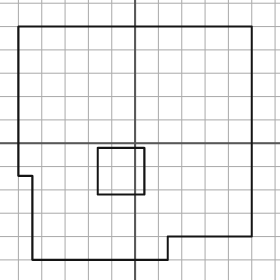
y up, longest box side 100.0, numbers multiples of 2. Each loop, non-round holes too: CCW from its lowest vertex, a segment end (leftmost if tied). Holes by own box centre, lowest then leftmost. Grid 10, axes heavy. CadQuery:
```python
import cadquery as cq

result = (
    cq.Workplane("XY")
    .moveTo(-44.0, -50.0)
    .lineTo(14.0, -50.0)
    .lineTo(14.0, -40.0)
    .lineTo(50.0, -40.0)
    .lineTo(50.0, 50.0)
    .lineTo(-50.0, 50.0)
    .lineTo(-50.0, -14.0)
    .lineTo(-44.0, -14.0)
    .close()
    .moveTo(-16.0, -22.0)
    .lineTo(4.0, -22.0)
    .lineTo(4.0, -2.0)
    .lineTo(-16.0, -2.0)
    .close()
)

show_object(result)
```